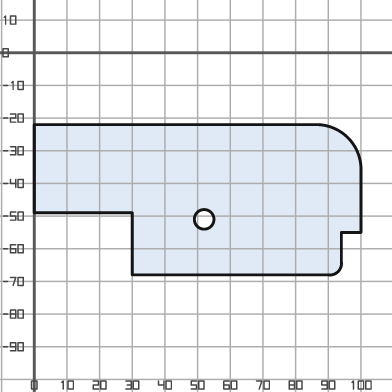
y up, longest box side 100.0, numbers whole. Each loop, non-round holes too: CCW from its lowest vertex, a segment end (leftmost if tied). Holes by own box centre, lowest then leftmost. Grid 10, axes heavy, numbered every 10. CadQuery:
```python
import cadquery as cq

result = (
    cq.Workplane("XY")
    .moveTo(30.0, -68.0)
    .lineTo(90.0, -68.0)
    .threePointArc((93.0, -67.0), (94.0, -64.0))
    .lineTo(94.0, -55.0)
    .lineTo(100.0, -55.0)
    .lineTo(100.0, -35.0)
    .threePointArc((96.0, -26.0), (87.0, -22.0))
    .lineTo(0.0, -22.0)
    .lineTo(0.0, -49.0)
    .lineTo(30.0, -49.0)
    .close()
    .moveTo(52.0, -51.0)
    .circle(3.0)
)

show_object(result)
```